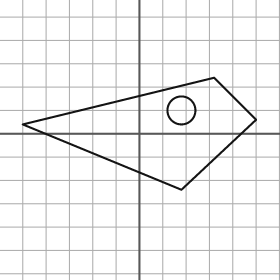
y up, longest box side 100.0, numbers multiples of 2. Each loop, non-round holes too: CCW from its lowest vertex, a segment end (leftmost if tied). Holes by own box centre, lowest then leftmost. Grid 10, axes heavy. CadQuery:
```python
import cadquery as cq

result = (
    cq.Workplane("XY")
    .moveTo(18.0, -24.0)
    .lineTo(50.0, 6.0)
    .lineTo(32.0, 24.0)
    .lineTo(-50.0, 4.0)
    .close()
    .moveTo(18.0, 10.0)
    .circle(6.0)
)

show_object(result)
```